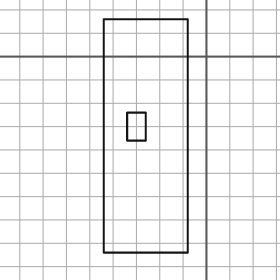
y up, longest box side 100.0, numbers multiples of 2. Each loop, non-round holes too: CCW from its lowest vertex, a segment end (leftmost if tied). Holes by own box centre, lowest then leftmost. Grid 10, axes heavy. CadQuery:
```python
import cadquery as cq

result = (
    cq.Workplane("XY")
    .moveTo(-44.0, -84.0)
    .lineTo(-8.0, -84.0)
    .lineTo(-8.0, 16.0)
    .lineTo(-44.0, 16.0)
    .close()
    .moveTo(-34.0, -36.0)
    .lineTo(-26.0, -36.0)
    .lineTo(-26.0, -24.0)
    .lineTo(-34.0, -24.0)
    .close()
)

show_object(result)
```